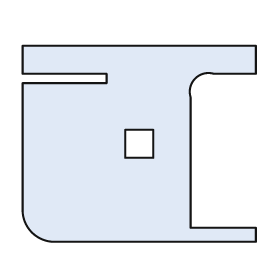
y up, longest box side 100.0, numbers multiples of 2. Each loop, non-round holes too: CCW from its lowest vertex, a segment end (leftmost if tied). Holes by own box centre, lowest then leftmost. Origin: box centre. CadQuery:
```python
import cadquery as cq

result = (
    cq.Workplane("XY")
    .moveTo(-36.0, -42.0)
    .lineTo(50.0, -42.0)
    .lineTo(50.0, -36.0)
    .lineTo(22.0, -36.0)
    .lineTo(22.0, 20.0)
    .threePointArc((24.0, 28.0), (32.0, 30.0))
    .lineTo(50.0, 30.0)
    .lineTo(50.0, 42.0)
    .lineTo(-50.0, 42.0)
    .lineTo(-50.0, 30.0)
    .lineTo(-14.0, 30.0)
    .lineTo(-14.0, 26.0)
    .lineTo(-50.0, 26.0)
    .lineTo(-50.0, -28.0)
    .threePointArc((-46.0, -38.0), (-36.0, -42.0))
    .close()
    .moveTo(-6.0, -6.0)
    .lineTo(6.0, -6.0)
    .lineTo(6.0, 6.0)
    .lineTo(-6.0, 6.0)
    .close()
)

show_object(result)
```